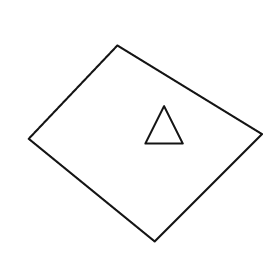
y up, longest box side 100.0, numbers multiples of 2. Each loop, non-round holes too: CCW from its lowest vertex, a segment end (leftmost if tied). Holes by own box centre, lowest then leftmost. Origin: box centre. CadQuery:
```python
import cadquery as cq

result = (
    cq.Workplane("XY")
    .moveTo(4.0, -42.0)
    .lineTo(50.0, 4.0)
    .lineTo(-12.0, 42.0)
    .lineTo(-50.0, 2.0)
    .close()
    .moveTo(0.0, 0.0)
    .lineTo(16.0, 0.0)
    .lineTo(8.0, 16.0)
    .close()
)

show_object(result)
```